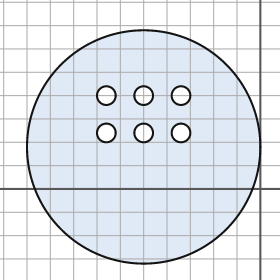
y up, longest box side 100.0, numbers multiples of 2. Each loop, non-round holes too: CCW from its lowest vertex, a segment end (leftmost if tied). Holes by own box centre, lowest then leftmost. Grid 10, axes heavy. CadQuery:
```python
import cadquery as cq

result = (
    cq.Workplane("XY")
    .moveTo(-50.0, 18.0)
    .circle(50.0)
    .moveTo(-66.0, 24.0)
    .circle(4.0)
    .moveTo(-50.0, 24.0)
    .circle(4.0)
    .moveTo(-34.0, 24.0)
    .circle(4.0)
    .moveTo(-66.0, 40.0)
    .circle(4.0)
    .moveTo(-50.0, 40.0)
    .circle(4.0)
    .moveTo(-34.0, 40.0)
    .circle(4.0)
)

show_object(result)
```